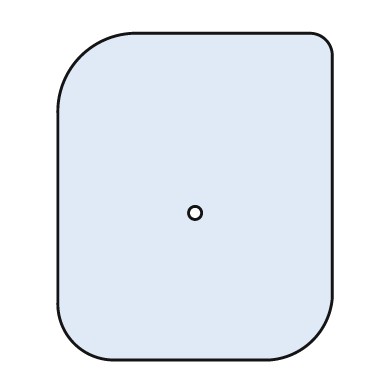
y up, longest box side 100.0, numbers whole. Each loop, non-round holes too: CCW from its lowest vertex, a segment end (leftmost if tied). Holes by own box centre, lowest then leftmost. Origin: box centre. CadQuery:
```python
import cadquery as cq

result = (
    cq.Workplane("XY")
    .moveTo(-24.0, -50.0)
    .lineTo(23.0, -50.0)
    .threePointArc((36.0, -44.0), (42.0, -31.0))
    .lineTo(42.0, 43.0)
    .threePointArc((40.0, 48.0), (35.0, 50.0))
    .lineTo(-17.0, 50.0)
    .threePointArc((-35.0, 43.0), (-42.0, 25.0))
    .lineTo(-42.0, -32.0)
    .threePointArc((-37.0, -45.0), (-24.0, -50.0))
    .close()
    .moveTo(0.0, -5.0)
    .circle(2.0)
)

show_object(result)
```